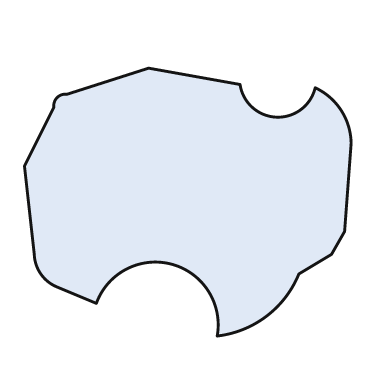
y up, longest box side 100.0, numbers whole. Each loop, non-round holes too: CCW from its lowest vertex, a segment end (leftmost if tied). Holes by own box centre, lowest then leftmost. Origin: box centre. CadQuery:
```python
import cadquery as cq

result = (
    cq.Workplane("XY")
    .moveTo(9.0, -41.0)
    .threePointArc((24.0, -35.0), (34.0, -22.0))
    .lineTo(44.0, -16.0)
    .lineTo(48.0, -9.0)
    .lineTo(50.0, 18.0)
    .threePointArc((47.0, 28.0), (39.0, 35.0))
    .threePointArc((27.0, 26.0), (16.0, 36.0))
    .lineTo(-12.0, 41.0)
    .lineTo(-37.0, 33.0)
    .threePointArc((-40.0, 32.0), (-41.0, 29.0))
    .lineTo(-50.0, 11.0)
    .lineTo(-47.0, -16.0)
    .threePointArc((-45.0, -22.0), (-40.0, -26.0))
    .lineTo(-28.0, -31.0)
    .threePointArc((-5.0, -19.0), (9.0, -41.0))
    .close()
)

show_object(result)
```